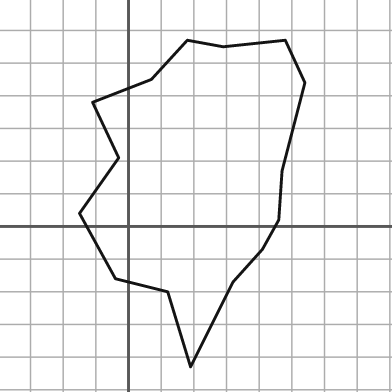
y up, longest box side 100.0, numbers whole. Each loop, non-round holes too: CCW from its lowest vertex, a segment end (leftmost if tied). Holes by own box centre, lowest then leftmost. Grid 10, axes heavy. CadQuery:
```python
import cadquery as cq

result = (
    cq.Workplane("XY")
    .moveTo(19.0, -43.0)
    .lineTo(32.0, -17.0)
    .lineTo(41.0, -7.0)
    .lineTo(46.0, 2.0)
    .lineTo(47.0, 17.0)
    .lineTo(54.0, 44.0)
    .lineTo(48.0, 57.0)
    .lineTo(29.0, 55.0)
    .lineTo(18.0, 57.0)
    .lineTo(7.0, 45.0)
    .lineTo(-11.0, 38.0)
    .lineTo(-3.0, 21.0)
    .lineTo(-15.0, 4.0)
    .lineTo(-4.0, -16.0)
    .lineTo(12.0, -20.0)
    .close()
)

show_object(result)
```